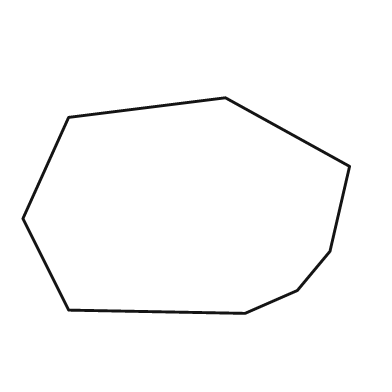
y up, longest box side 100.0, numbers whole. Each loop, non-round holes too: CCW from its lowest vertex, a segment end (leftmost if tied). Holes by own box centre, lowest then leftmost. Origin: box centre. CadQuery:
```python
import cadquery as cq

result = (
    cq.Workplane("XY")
    .moveTo(18.0, -33.0)
    .lineTo(34.0, -26.0)
    .lineTo(44.0, -14.0)
    .lineTo(50.0, 12.0)
    .lineTo(12.0, 33.0)
    .lineTo(-36.0, 27.0)
    .lineTo(-50.0, -4.0)
    .lineTo(-36.0, -32.0)
    .close()
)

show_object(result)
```